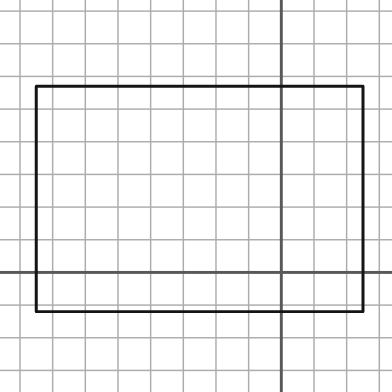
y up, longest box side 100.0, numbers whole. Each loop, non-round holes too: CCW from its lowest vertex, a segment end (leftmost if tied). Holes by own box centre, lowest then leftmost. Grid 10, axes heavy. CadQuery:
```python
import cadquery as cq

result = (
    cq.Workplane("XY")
    .moveTo(-75.0, -12.0)
    .lineTo(25.0, -12.0)
    .lineTo(25.0, 57.0)
    .lineTo(-75.0, 57.0)
    .close()
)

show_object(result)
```